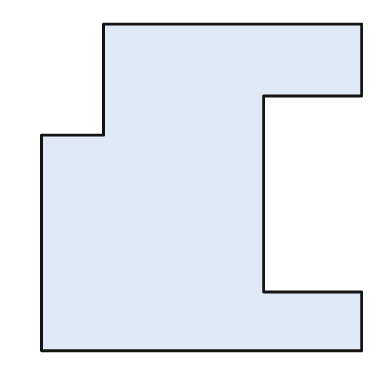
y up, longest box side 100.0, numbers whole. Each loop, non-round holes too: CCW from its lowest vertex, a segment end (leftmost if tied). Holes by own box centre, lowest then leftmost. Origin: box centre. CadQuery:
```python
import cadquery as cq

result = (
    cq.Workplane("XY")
    .moveTo(-49.0, -50.0)
    .lineTo(49.0, -50.0)
    .lineTo(49.0, -32.0)
    .lineTo(19.0, -32.0)
    .lineTo(19.0, 28.0)
    .lineTo(49.0, 28.0)
    .lineTo(49.0, 50.0)
    .lineTo(-30.0, 50.0)
    .lineTo(-30.0, 16.0)
    .lineTo(-49.0, 16.0)
    .close()
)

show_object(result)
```